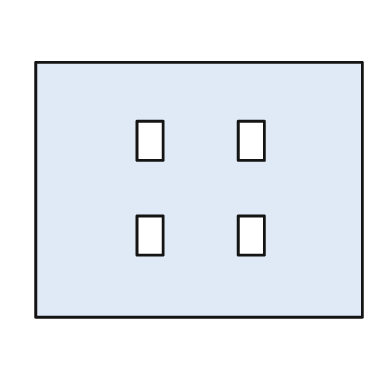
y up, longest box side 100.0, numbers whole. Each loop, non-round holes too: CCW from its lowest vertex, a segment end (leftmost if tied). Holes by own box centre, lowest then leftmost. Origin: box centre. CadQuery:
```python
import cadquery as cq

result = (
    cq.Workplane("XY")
    .moveTo(-50.0, -39.0)
    .lineTo(50.0, -39.0)
    .lineTo(50.0, 39.0)
    .lineTo(-50.0, 39.0)
    .close()
    .moveTo(-19.0, -20.0)
    .lineTo(-11.0, -20.0)
    .lineTo(-11.0, -8.0)
    .lineTo(-19.0, -8.0)
    .close()
    .moveTo(12.0, -20.0)
    .lineTo(20.0, -20.0)
    .lineTo(20.0, -8.0)
    .lineTo(12.0, -8.0)
    .close()
    .moveTo(-19.0, 9.0)
    .lineTo(-11.0, 9.0)
    .lineTo(-11.0, 21.0)
    .lineTo(-19.0, 21.0)
    .close()
    .moveTo(12.0, 9.0)
    .lineTo(20.0, 9.0)
    .lineTo(20.0, 21.0)
    .lineTo(12.0, 21.0)
    .close()
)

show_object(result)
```